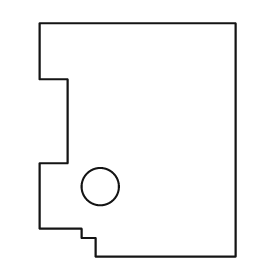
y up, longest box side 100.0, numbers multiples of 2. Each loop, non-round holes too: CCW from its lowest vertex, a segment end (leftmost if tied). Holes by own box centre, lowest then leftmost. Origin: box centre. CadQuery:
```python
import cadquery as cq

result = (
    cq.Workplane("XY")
    .moveTo(-18.0, -50.0)
    .lineTo(42.0, -50.0)
    .lineTo(42.0, 50.0)
    .lineTo(-42.0, 50.0)
    .lineTo(-42.0, 26.0)
    .lineTo(-30.0, 26.0)
    .lineTo(-30.0, -10.0)
    .lineTo(-42.0, -10.0)
    .lineTo(-42.0, -38.0)
    .lineTo(-24.0, -38.0)
    .lineTo(-24.0, -42.0)
    .lineTo(-18.0, -42.0)
    .close()
    .moveTo(-16.0, -20.0)
    .circle(8.0)
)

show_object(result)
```